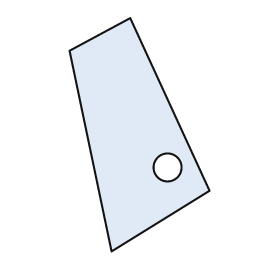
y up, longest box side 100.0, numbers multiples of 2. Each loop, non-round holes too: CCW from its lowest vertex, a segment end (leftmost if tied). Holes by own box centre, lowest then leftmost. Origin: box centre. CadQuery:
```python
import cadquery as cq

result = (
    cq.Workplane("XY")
    .moveTo(-12.0, -50.0)
    .lineTo(30.0, -24.0)
    .lineTo(-4.0, 50.0)
    .lineTo(-30.0, 36.0)
    .close()
    .moveTo(12.0, -14.0)
    .circle(6.0)
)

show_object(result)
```